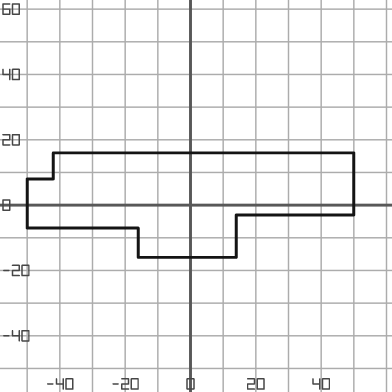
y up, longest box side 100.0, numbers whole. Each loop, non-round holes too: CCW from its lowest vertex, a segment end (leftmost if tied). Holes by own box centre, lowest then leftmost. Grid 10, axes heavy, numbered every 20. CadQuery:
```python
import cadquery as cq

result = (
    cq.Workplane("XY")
    .moveTo(-16.0, -16.0)
    .lineTo(14.0, -16.0)
    .lineTo(14.0, -3.0)
    .lineTo(50.0, -3.0)
    .lineTo(50.0, 16.0)
    .lineTo(-42.0, 16.0)
    .lineTo(-42.0, 8.0)
    .lineTo(-50.0, 8.0)
    .lineTo(-50.0, -7.0)
    .lineTo(-16.0, -7.0)
    .close()
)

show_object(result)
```